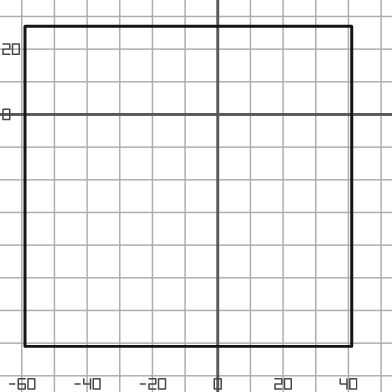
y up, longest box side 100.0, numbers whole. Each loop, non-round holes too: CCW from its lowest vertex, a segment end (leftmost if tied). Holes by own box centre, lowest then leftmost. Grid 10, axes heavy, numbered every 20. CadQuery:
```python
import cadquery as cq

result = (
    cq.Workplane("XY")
    .moveTo(-59.0, -71.0)
    .lineTo(41.0, -71.0)
    .lineTo(41.0, 27.0)
    .lineTo(-59.0, 27.0)
    .close()
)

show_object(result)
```